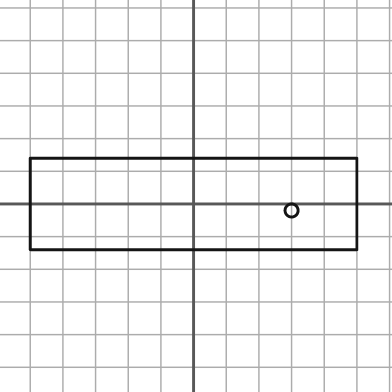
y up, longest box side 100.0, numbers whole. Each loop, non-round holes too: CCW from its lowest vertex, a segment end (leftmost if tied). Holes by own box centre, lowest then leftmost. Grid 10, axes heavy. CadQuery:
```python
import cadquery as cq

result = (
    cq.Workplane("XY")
    .moveTo(-50.0, -14.0)
    .lineTo(50.0, -14.0)
    .lineTo(50.0, 14.0)
    .lineTo(-50.0, 14.0)
    .close()
    .moveTo(30.0, -2.0)
    .circle(2.0)
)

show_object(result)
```